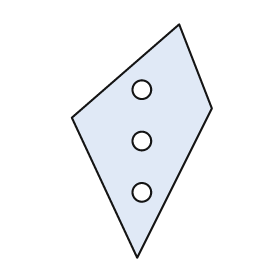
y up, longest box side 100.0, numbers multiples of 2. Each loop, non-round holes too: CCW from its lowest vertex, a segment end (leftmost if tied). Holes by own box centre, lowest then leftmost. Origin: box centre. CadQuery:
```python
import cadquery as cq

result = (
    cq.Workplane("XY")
    .moveTo(-2.0, -50.0)
    .lineTo(30.0, 14.0)
    .lineTo(16.0, 50.0)
    .lineTo(-30.0, 10.0)
    .close()
    .moveTo(0.0, -22.0)
    .circle(4.0)
    .moveTo(0.0, 0.0)
    .circle(4.0)
    .moveTo(0.0, 22.0)
    .circle(4.0)
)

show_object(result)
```